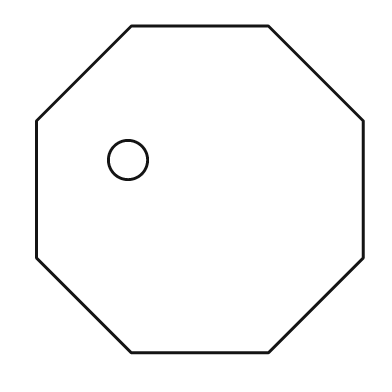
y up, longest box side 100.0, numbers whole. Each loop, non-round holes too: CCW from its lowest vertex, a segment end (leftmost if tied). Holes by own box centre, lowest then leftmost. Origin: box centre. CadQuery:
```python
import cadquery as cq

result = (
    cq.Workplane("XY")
    .moveTo(-21.0, -50.0)
    .lineTo(21.0, -50.0)
    .lineTo(50.0, -21.0)
    .lineTo(50.0, 21.0)
    .lineTo(21.0, 50.0)
    .lineTo(-21.0, 50.0)
    .lineTo(-50.0, 21.0)
    .lineTo(-50.0, -21.0)
    .close()
    .moveTo(-22.0, 9.0)
    .circle(6.0)
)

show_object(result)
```